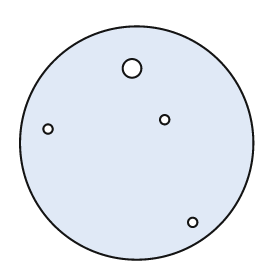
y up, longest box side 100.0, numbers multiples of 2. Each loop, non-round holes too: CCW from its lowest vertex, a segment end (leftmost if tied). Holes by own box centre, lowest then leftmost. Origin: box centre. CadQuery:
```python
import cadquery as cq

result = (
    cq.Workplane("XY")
    .moveTo(0.0, 0.0)
    .circle(50.0)
    .moveTo(24.0, -34.0)
    .circle(2.0)
    .moveTo(-38.0, 6.0)
    .circle(2.0)
    .moveTo(12.0, 10.0)
    .circle(2.0)
    .moveTo(-2.0, 32.0)
    .circle(4.0)
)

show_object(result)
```